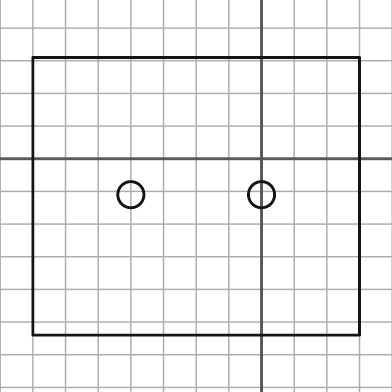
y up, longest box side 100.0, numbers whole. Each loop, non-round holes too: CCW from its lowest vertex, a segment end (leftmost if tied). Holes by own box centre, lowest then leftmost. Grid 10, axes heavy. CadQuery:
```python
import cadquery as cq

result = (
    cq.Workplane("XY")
    .moveTo(-70.0, -54.0)
    .lineTo(30.0, -54.0)
    .lineTo(30.0, 31.0)
    .lineTo(-70.0, 31.0)
    .close()
    .moveTo(-40.0, -11.0)
    .circle(4.0)
    .moveTo(0.0, -11.0)
    .circle(4.0)
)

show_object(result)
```